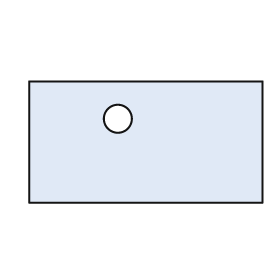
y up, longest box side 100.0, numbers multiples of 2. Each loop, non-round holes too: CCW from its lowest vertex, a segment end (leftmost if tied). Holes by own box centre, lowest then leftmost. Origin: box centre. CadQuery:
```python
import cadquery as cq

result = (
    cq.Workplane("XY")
    .moveTo(-50.0, -26.0)
    .lineTo(50.0, -26.0)
    .lineTo(50.0, 26.0)
    .lineTo(-50.0, 26.0)
    .close()
    .moveTo(-12.0, 10.0)
    .circle(6.0)
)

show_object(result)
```